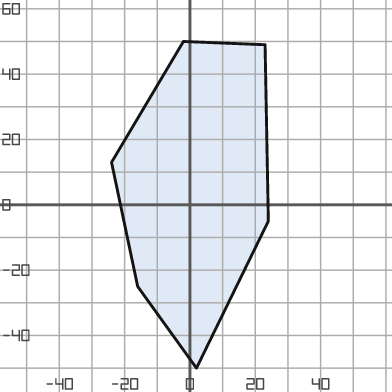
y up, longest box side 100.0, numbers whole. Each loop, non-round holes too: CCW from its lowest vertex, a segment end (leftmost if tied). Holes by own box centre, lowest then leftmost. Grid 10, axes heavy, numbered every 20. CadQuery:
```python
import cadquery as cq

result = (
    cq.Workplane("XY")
    .moveTo(2.0, -50.0)
    .lineTo(24.0, -5.0)
    .lineTo(23.0, 49.0)
    .lineTo(-2.0, 50.0)
    .lineTo(-24.0, 13.0)
    .lineTo(-16.0, -25.0)
    .close()
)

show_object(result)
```